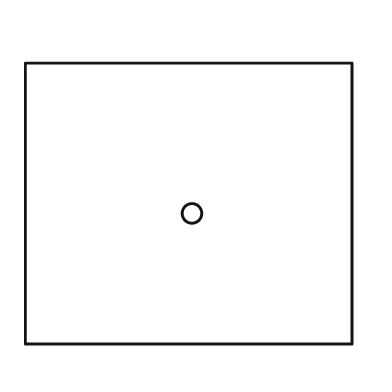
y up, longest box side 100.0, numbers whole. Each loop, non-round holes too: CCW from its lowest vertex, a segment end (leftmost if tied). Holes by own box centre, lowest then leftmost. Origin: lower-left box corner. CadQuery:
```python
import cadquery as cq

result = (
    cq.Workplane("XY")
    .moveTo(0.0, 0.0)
    .lineTo(100.0, 0.0)
    .lineTo(100.0, 86.0)
    .lineTo(0.0, 86.0)
    .close()
    .moveTo(51.0, 40.0)
    .circle(3.0)
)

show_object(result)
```